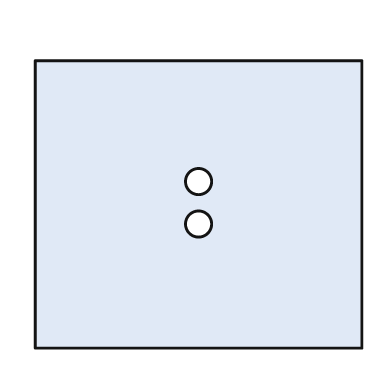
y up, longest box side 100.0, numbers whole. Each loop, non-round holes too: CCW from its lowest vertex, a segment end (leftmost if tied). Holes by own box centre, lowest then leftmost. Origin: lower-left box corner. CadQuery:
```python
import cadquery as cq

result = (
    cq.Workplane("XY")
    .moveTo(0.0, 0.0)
    .lineTo(100.0, 0.0)
    .lineTo(100.0, 88.0)
    .lineTo(0.0, 88.0)
    .close()
    .moveTo(50.0, 38.0)
    .circle(4.0)
    .moveTo(50.0, 51.0)
    .circle(4.0)
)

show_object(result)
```